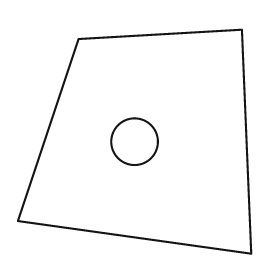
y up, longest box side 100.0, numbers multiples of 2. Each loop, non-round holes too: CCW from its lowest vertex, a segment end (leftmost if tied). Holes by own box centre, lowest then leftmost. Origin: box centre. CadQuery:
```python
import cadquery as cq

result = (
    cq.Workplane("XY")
    .moveTo(50.0, -48.0)
    .lineTo(46.0, 48.0)
    .lineTo(-24.0, 44.0)
    .lineTo(-50.0, -34.0)
    .close()
    .moveTo(0.0, 0.0)
    .circle(10.0)
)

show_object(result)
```